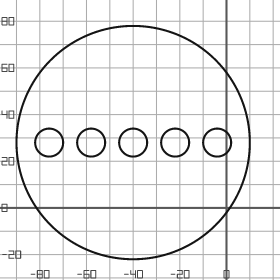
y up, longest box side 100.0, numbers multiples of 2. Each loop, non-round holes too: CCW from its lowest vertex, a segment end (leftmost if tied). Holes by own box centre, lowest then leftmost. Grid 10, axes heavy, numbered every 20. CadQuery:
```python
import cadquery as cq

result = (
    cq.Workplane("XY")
    .moveTo(-40.0, 28.0)
    .circle(50.0)
    .moveTo(-76.0, 28.0)
    .circle(6.0)
    .moveTo(-58.0, 28.0)
    .circle(6.0)
    .moveTo(-40.0, 28.0)
    .circle(6.0)
    .moveTo(-22.0, 28.0)
    .circle(6.0)
    .moveTo(-4.0, 28.0)
    .circle(6.0)
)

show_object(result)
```